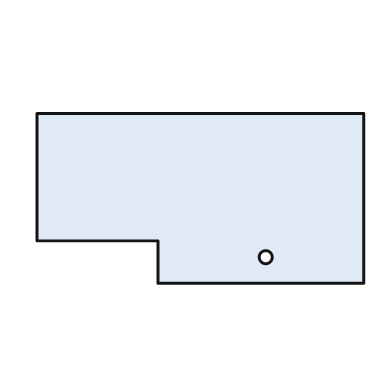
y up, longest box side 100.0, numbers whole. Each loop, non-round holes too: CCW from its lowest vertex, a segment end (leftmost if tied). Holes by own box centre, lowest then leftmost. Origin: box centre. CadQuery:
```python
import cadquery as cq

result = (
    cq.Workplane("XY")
    .moveTo(-13.0, -26.0)
    .lineTo(50.0, -26.0)
    .lineTo(50.0, 26.0)
    .lineTo(-50.0, 26.0)
    .lineTo(-50.0, -13.0)
    .lineTo(-13.0, -13.0)
    .close()
    .moveTo(20.0, -18.0)
    .circle(2.0)
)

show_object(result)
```